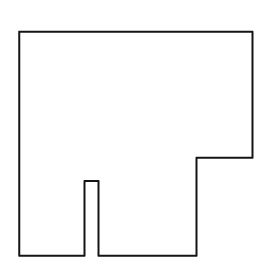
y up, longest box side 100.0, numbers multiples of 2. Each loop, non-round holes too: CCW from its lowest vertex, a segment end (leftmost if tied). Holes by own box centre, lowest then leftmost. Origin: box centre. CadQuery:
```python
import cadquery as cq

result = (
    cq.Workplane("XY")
    .moveTo(-50.0, -48.0)
    .lineTo(-22.0, -48.0)
    .lineTo(-22.0, -16.0)
    .lineTo(-16.0, -16.0)
    .lineTo(-16.0, -48.0)
    .lineTo(26.0, -48.0)
    .lineTo(26.0, -6.0)
    .lineTo(50.0, -6.0)
    .lineTo(50.0, 48.0)
    .lineTo(-50.0, 48.0)
    .close()
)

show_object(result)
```